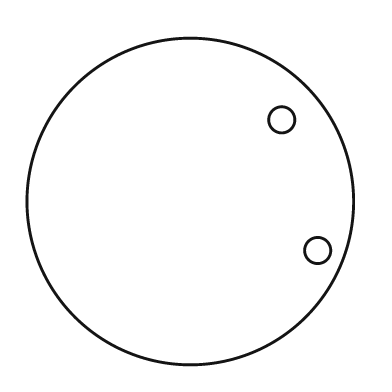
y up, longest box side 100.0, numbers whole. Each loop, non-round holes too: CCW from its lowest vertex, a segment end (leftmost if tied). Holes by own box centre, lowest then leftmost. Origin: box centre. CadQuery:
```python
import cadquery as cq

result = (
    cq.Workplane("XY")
    .moveTo(0.0, 0.0)
    .circle(50.0)
    .moveTo(39.0, -15.0)
    .circle(4.0)
    .moveTo(28.0, 25.0)
    .circle(4.0)
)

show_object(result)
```